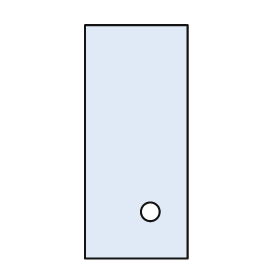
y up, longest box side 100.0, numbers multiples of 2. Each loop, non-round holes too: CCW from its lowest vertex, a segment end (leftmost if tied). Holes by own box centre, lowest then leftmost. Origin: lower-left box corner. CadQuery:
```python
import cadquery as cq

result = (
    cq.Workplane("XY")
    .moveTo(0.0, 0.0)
    .lineTo(44.0, 0.0)
    .lineTo(44.0, 100.0)
    .lineTo(0.0, 100.0)
    .close()
    .moveTo(28.0, 20.0)
    .circle(4.0)
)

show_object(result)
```